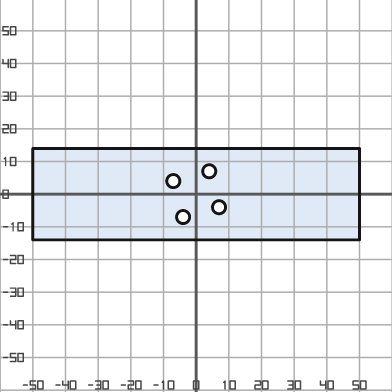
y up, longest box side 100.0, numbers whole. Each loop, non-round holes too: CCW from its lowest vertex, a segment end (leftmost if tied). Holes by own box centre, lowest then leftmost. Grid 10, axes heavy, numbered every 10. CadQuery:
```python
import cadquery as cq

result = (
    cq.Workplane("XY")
    .moveTo(-50.0, -14.0)
    .lineTo(50.0, -14.0)
    .lineTo(50.0, 14.0)
    .lineTo(-50.0, 14.0)
    .close()
    .moveTo(-4.0, -7.0)
    .circle(2.0)
    .moveTo(7.0, -4.0)
    .circle(2.0)
    .moveTo(-7.0, 4.0)
    .circle(2.0)
    .moveTo(4.0, 7.0)
    .circle(2.0)
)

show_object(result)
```